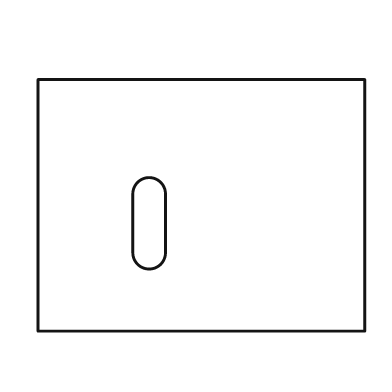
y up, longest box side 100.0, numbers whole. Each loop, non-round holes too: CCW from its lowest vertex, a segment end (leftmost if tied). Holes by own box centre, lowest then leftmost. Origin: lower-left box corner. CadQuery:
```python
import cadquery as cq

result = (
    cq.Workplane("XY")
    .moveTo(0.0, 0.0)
    .lineTo(100.0, 0.0)
    .lineTo(100.0, 77.0)
    .lineTo(0.0, 77.0)
    .close()
    .moveTo(29.0, 24.0)
    .threePointArc((34.0, 19.0), (39.0, 24.0))
    .lineTo(39.0, 42.0)
    .threePointArc((34.0, 47.0), (29.0, 42.0))
    .close()
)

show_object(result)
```